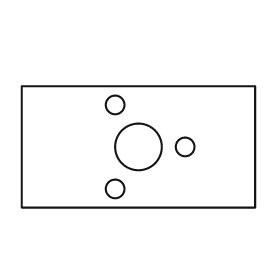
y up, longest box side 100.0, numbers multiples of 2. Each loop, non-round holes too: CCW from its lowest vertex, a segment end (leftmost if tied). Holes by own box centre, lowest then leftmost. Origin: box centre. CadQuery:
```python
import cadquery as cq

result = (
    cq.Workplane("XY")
    .moveTo(-50.0, -26.0)
    .lineTo(50.0, -26.0)
    .lineTo(50.0, 26.0)
    .lineTo(-50.0, 26.0)
    .close()
    .moveTo(-10.0, -18.0)
    .circle(4.0)
    .moveTo(0.0, 0.0)
    .circle(10.0)
    .moveTo(20.0, 0.0)
    .circle(4.0)
    .moveTo(-10.0, 18.0)
    .circle(4.0)
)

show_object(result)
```